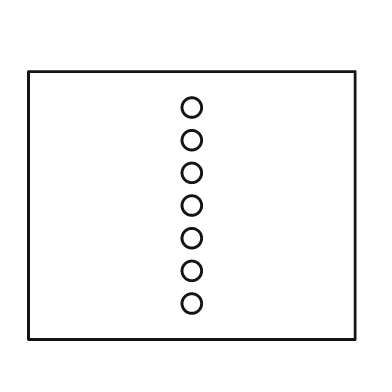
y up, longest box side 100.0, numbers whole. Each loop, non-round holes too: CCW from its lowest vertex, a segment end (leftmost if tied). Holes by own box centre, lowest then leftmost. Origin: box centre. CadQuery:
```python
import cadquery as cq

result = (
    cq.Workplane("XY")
    .moveTo(-50.0, -41.0)
    .lineTo(50.0, -41.0)
    .lineTo(50.0, 41.0)
    .lineTo(-50.0, 41.0)
    .close()
    .moveTo(0.0, -30.0)
    .circle(3.0)
    .moveTo(0.0, -20.0)
    .circle(3.0)
    .moveTo(0.0, -10.0)
    .circle(3.0)
    .moveTo(0.0, 0.0)
    .circle(3.0)
    .moveTo(0.0, 10.0)
    .circle(3.0)
    .moveTo(0.0, 20.0)
    .circle(3.0)
    .moveTo(0.0, 30.0)
    .circle(3.0)
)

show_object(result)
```